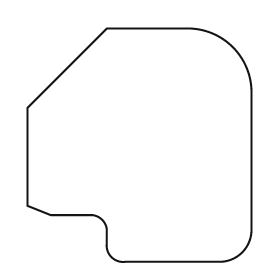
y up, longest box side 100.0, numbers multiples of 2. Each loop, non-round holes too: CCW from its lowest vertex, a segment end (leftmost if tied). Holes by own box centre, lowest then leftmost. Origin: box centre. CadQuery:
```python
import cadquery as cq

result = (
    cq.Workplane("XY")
    .moveTo(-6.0, -50.0)
    .lineTo(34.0, -50.0)
    .threePointArc((44.0, -46.0), (48.0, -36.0))
    .lineTo(48.0, 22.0)
    .threePointArc((40.0, 42.0), (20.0, 50.0))
    .lineTo(-14.0, 50.0)
    .lineTo(-48.0, 16.0)
    .lineTo(-48.0, -26.0)
    .lineTo(-38.0, -30.0)
    .lineTo(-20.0, -30.0)
    .threePointArc((-16.0, -32.0), (-14.0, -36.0))
    .lineTo(-14.0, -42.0)
    .threePointArc((-12.0, -48.0), (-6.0, -50.0))
    .close()
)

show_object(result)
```